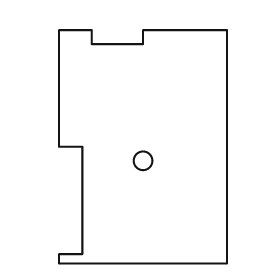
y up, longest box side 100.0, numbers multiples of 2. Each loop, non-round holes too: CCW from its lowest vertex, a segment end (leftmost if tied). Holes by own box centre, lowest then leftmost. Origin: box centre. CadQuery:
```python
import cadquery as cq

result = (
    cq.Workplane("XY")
    .moveTo(-36.0, -50.0)
    .lineTo(36.0, -50.0)
    .lineTo(36.0, 50.0)
    .lineTo(0.0, 50.0)
    .lineTo(0.0, 44.0)
    .lineTo(-22.0, 44.0)
    .lineTo(-22.0, 50.0)
    .lineTo(-36.0, 50.0)
    .lineTo(-36.0, 0.0)
    .lineTo(-26.0, 0.0)
    .lineTo(-26.0, -46.0)
    .lineTo(-36.0, -46.0)
    .close()
    .moveTo(0.0, -6.0)
    .circle(4.0)
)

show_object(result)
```